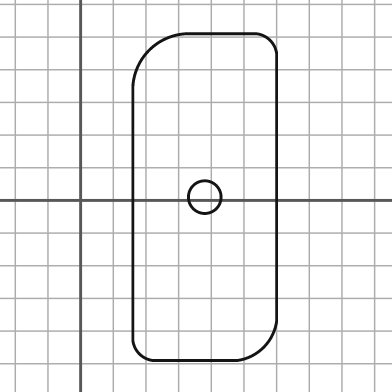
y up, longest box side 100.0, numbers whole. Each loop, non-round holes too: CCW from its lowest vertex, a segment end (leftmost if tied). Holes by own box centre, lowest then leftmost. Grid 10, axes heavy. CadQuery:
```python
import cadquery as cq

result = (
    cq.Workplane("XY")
    .moveTo(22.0, -49.0)
    .lineTo(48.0, -49.0)
    .threePointArc((56.0, -45.0), (60.0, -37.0))
    .lineTo(60.0, 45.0)
    .threePointArc((58.0, 49.0), (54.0, 51.0))
    .lineTo(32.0, 51.0)
    .threePointArc((21.0, 46.0), (16.0, 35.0))
    .lineTo(16.0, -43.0)
    .threePointArc((18.0, -47.0), (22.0, -49.0))
    .close()
    .moveTo(38.0, 1.0)
    .circle(5.0)
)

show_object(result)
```